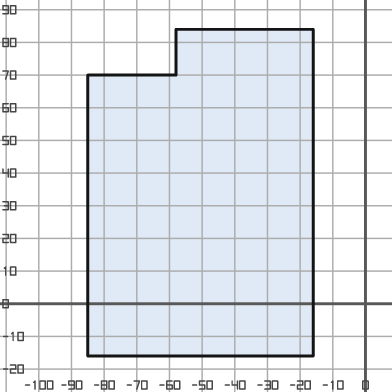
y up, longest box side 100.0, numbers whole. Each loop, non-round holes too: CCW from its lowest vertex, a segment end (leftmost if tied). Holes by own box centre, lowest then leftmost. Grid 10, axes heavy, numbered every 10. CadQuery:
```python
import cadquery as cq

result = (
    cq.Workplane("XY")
    .moveTo(-85.0, -16.0)
    .lineTo(-16.0, -16.0)
    .lineTo(-16.0, 84.0)
    .lineTo(-58.0, 84.0)
    .lineTo(-58.0, 70.0)
    .lineTo(-85.0, 70.0)
    .close()
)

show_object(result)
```